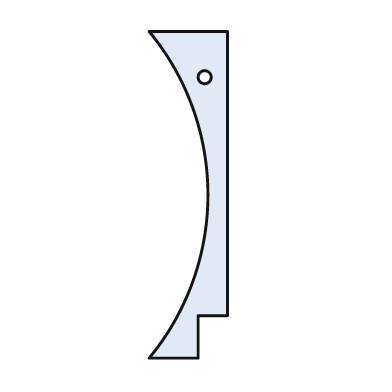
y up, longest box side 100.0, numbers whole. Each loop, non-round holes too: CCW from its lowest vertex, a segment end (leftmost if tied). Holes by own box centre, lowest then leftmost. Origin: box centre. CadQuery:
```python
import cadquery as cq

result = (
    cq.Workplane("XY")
    .moveTo(-12.0, -50.0)
    .lineTo(3.0, -50.0)
    .lineTo(3.0, -37.0)
    .lineTo(12.0, -37.0)
    .lineTo(12.0, 50.0)
    .lineTo(-12.0, 50.0)
    .threePointArc((6.0, 0.0), (-12.0, -50.0))
    .close()
    .moveTo(5.0, 36.0)
    .circle(2.0)
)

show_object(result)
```